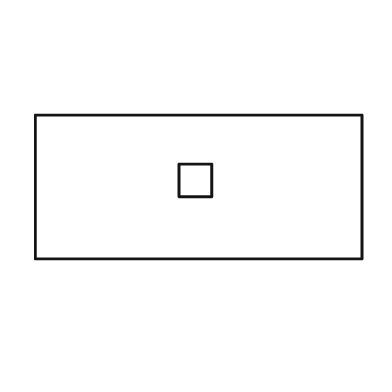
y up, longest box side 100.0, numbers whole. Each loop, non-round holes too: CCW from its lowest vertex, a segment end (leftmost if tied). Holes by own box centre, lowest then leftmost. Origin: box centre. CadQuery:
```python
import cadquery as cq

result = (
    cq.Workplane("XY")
    .moveTo(-50.0, -22.0)
    .lineTo(50.0, -22.0)
    .lineTo(50.0, 22.0)
    .lineTo(-50.0, 22.0)
    .close()
    .moveTo(-6.0, -3.0)
    .lineTo(4.0, -3.0)
    .lineTo(4.0, 7.0)
    .lineTo(-6.0, 7.0)
    .close()
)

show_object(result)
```